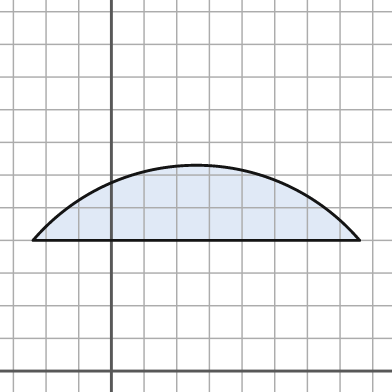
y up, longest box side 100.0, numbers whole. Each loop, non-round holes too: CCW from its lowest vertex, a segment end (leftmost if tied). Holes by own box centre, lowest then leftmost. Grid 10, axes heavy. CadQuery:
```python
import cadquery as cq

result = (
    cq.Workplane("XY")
    .moveTo(-24.0, 40.0)
    .lineTo(76.0, 40.0)
    .threePointArc((26.0, 63.0), (-24.0, 40.0))
    .close()
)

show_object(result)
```